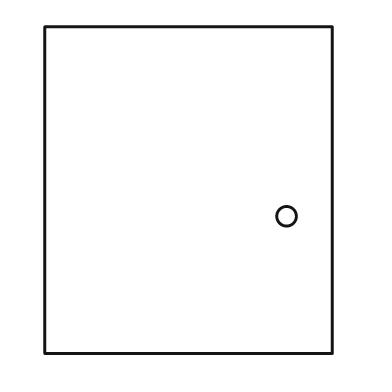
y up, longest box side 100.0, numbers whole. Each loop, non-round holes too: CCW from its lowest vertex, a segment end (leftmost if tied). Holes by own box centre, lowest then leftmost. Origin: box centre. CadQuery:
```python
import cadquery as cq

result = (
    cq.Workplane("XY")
    .moveTo(-44.0, -50.0)
    .lineTo(44.0, -50.0)
    .lineTo(44.0, 50.0)
    .lineTo(-44.0, 50.0)
    .close()
    .moveTo(30.0, -8.0)
    .circle(3.0)
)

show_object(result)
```